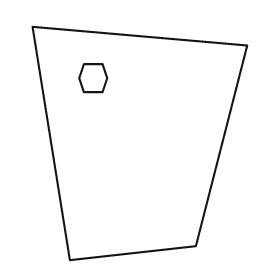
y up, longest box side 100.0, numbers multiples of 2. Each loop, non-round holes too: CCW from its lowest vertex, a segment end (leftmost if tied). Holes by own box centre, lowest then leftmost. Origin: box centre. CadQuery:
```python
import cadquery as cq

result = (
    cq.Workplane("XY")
    .moveTo(-30.0, -50.0)
    .lineTo(24.0, -44.0)
    .lineTo(46.0, 42.0)
    .lineTo(-46.0, 50.0)
    .close()
    .moveTo(-24.0, 22.0)
    .lineTo(-16.0, 22.0)
    .lineTo(-14.0, 28.0)
    .lineTo(-16.0, 34.0)
    .lineTo(-24.0, 34.0)
    .lineTo(-26.0, 28.0)
    .close()
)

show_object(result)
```